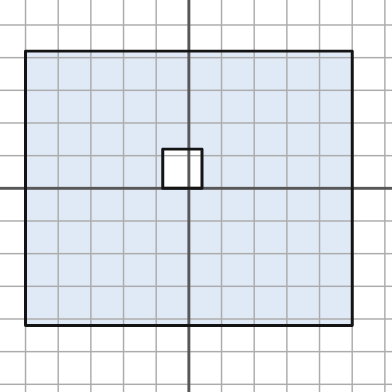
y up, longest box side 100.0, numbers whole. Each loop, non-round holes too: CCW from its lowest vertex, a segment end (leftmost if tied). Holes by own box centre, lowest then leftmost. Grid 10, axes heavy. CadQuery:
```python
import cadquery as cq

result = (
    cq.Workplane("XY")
    .moveTo(-50.0, -42.0)
    .lineTo(50.0, -42.0)
    .lineTo(50.0, 42.0)
    .lineTo(-50.0, 42.0)
    .close()
    .moveTo(-8.0, 0.0)
    .lineTo(4.0, 0.0)
    .lineTo(4.0, 12.0)
    .lineTo(-8.0, 12.0)
    .close()
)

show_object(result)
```